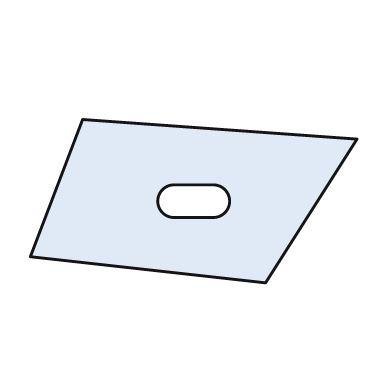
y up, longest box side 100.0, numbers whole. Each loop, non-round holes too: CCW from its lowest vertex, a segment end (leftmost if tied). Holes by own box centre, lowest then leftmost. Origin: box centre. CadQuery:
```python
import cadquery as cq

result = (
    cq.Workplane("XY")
    .moveTo(22.0, -25.0)
    .lineTo(50.0, 19.0)
    .lineTo(-34.0, 25.0)
    .lineTo(-50.0, -17.0)
    .close()
    .moveTo(-6.0, -5.0)
    .lineTo(6.0, -5.0)
    .threePointArc((11.0, 0.0), (6.0, 5.0))
    .lineTo(-6.0, 5.0)
    .threePointArc((-11.0, 0.0), (-6.0, -5.0))
    .close()
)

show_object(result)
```